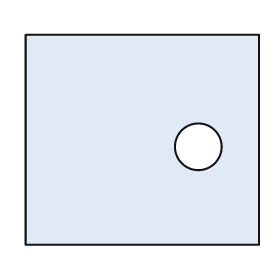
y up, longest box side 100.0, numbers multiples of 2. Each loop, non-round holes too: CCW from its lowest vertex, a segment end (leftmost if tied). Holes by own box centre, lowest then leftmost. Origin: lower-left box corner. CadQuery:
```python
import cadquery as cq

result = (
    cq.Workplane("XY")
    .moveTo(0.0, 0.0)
    .lineTo(100.0, 0.0)
    .lineTo(100.0, 90.0)
    .lineTo(0.0, 90.0)
    .close()
    .moveTo(74.0, 42.0)
    .circle(10.0)
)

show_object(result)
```